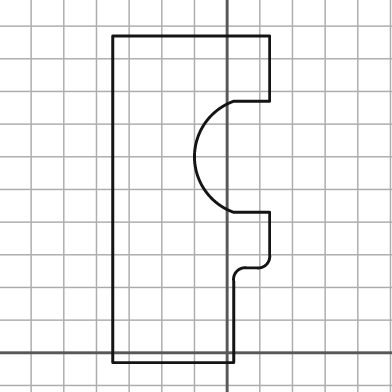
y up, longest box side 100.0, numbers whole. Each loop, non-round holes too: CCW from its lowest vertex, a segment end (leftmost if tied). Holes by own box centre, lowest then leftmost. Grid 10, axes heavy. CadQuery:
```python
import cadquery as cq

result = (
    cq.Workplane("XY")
    .moveTo(-35.0, -3.0)
    .lineTo(2.0, -3.0)
    .lineTo(2.0, 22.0)
    .threePointArc((3.0, 25.0), (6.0, 26.0))
    .lineTo(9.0, 26.0)
    .threePointArc((12.0, 27.0), (13.0, 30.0))
    .lineTo(13.0, 43.0)
    .lineTo(2.0, 43.0)
    .threePointArc((-10.0, 60.0), (2.0, 77.0))
    .lineTo(13.0, 77.0)
    .lineTo(13.0, 97.0)
    .lineTo(-35.0, 97.0)
    .close()
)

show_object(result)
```